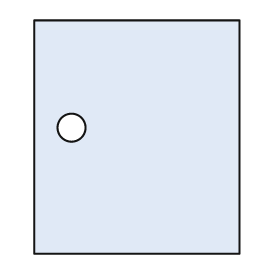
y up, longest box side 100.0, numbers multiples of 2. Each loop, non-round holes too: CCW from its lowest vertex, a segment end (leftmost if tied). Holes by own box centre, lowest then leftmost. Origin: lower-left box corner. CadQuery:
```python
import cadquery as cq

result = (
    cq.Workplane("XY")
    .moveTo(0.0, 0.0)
    .lineTo(88.0, 0.0)
    .lineTo(88.0, 100.0)
    .lineTo(0.0, 100.0)
    .close()
    .moveTo(16.0, 54.0)
    .circle(6.0)
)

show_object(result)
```